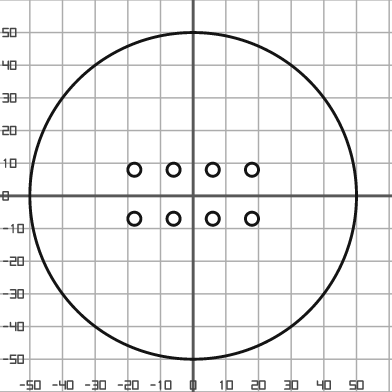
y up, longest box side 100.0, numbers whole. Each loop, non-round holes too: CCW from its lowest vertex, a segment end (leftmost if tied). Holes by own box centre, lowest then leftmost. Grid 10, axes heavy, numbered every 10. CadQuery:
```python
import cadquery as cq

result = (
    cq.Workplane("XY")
    .moveTo(0.0, 0.0)
    .circle(50.0)
    .moveTo(-18.0, -7.0)
    .circle(2.0)
    .moveTo(-6.0, -7.0)
    .circle(2.0)
    .moveTo(6.0, -7.0)
    .circle(2.0)
    .moveTo(18.0, -7.0)
    .circle(2.0)
    .moveTo(-18.0, 8.0)
    .circle(2.0)
    .moveTo(-6.0, 8.0)
    .circle(2.0)
    .moveTo(6.0, 8.0)
    .circle(2.0)
    .moveTo(18.0, 8.0)
    .circle(2.0)
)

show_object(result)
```